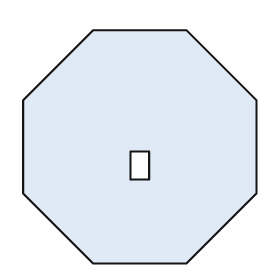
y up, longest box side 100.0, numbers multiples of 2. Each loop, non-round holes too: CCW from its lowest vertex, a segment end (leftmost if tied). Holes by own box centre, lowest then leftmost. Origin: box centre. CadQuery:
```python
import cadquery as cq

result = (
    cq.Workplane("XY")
    .moveTo(-20.0, -50.0)
    .lineTo(20.0, -50.0)
    .lineTo(50.0, -20.0)
    .lineTo(50.0, 20.0)
    .lineTo(20.0, 50.0)
    .lineTo(-20.0, 50.0)
    .lineTo(-50.0, 20.0)
    .lineTo(-50.0, -20.0)
    .close()
    .moveTo(-4.0, -14.0)
    .lineTo(4.0, -14.0)
    .lineTo(4.0, -2.0)
    .lineTo(-4.0, -2.0)
    .close()
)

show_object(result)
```